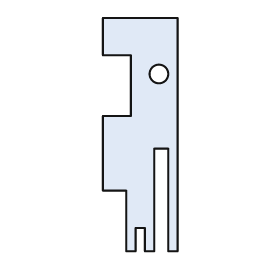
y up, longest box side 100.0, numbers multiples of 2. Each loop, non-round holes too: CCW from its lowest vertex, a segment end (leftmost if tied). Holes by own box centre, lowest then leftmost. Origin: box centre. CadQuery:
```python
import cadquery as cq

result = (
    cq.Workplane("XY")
    .moveTo(-6.0, -50.0)
    .lineTo(-2.0, -50.0)
    .lineTo(-2.0, -40.0)
    .lineTo(2.0, -40.0)
    .lineTo(2.0, -50.0)
    .lineTo(6.0, -50.0)
    .lineTo(6.0, -6.0)
    .lineTo(12.0, -6.0)
    .lineTo(12.0, -50.0)
    .lineTo(16.0, -50.0)
    .lineTo(16.0, 50.0)
    .lineTo(-16.0, 50.0)
    .lineTo(-16.0, 34.0)
    .lineTo(-4.0, 34.0)
    .lineTo(-4.0, 8.0)
    .lineTo(-16.0, 8.0)
    .lineTo(-16.0, -24.0)
    .lineTo(-6.0, -24.0)
    .close()
    .moveTo(8.0, 26.0)
    .circle(4.0)
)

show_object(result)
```